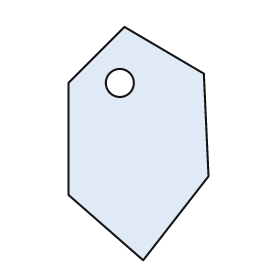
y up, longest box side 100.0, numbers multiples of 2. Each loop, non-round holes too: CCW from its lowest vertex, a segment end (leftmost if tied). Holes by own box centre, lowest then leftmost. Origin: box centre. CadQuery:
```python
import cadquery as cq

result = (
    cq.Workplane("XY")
    .moveTo(2.0, -50.0)
    .lineTo(30.0, -14.0)
    .lineTo(28.0, 30.0)
    .lineTo(-6.0, 50.0)
    .lineTo(-30.0, 26.0)
    .lineTo(-30.0, -22.0)
    .close()
    .moveTo(-8.0, 26.0)
    .circle(6.0)
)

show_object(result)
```